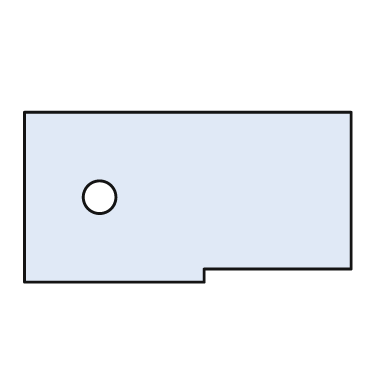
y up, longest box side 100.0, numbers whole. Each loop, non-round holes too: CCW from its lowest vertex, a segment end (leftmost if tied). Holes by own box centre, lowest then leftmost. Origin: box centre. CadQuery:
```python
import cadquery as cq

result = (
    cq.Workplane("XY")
    .moveTo(-50.0, -26.0)
    .lineTo(5.0, -26.0)
    .lineTo(5.0, -22.0)
    .lineTo(50.0, -22.0)
    .lineTo(50.0, 26.0)
    .lineTo(-50.0, 26.0)
    .close()
    .moveTo(-27.0, 0.0)
    .circle(5.0)
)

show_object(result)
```